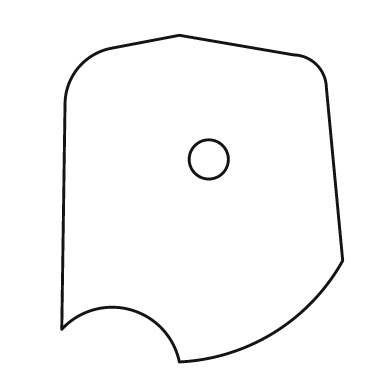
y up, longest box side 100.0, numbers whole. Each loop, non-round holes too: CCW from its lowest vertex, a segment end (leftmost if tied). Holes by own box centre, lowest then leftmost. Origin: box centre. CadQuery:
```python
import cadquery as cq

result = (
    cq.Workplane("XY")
    .moveTo(-7.0, -50.0)
    .threePointArc((22.0, -41.0), (43.0, -19.0))
    .lineTo(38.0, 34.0)
    .threePointArc((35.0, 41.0), (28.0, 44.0))
    .lineTo(-7.0, 50.0)
    .lineTo(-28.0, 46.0)
    .threePointArc((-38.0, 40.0), (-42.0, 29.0))
    .lineTo(-43.0, -40.0)
    .threePointArc((-22.0, -34.0), (-7.0, -50.0))
    .close()
    .moveTo(2.0, 12.0)
    .circle(6.0)
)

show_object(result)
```